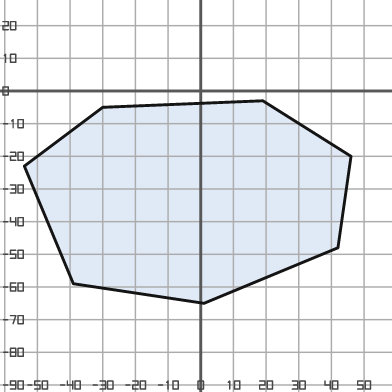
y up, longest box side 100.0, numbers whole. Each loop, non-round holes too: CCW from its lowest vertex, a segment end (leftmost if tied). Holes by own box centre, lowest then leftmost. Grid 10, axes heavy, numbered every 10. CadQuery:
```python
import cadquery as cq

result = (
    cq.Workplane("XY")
    .moveTo(1.0, -65.0)
    .lineTo(42.0, -48.0)
    .lineTo(46.0, -20.0)
    .lineTo(19.0, -3.0)
    .lineTo(-30.0, -5.0)
    .lineTo(-54.0, -23.0)
    .lineTo(-39.0, -59.0)
    .close()
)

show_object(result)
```